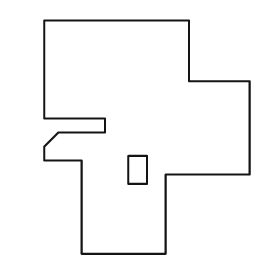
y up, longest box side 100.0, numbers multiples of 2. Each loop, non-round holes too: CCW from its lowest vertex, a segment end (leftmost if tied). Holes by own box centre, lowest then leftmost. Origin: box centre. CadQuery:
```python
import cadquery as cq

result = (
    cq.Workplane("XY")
    .moveTo(-28.0, -50.0)
    .lineTo(8.0, -50.0)
    .lineTo(8.0, -16.0)
    .lineTo(44.0, -16.0)
    .lineTo(44.0, 24.0)
    .lineTo(18.0, 24.0)
    .lineTo(18.0, 50.0)
    .lineTo(-44.0, 50.0)
    .lineTo(-44.0, 8.0)
    .lineTo(-18.0, 8.0)
    .lineTo(-18.0, 2.0)
    .lineTo(-38.0, 2.0)
    .lineTo(-44.0, -4.0)
    .lineTo(-44.0, -10.0)
    .lineTo(-28.0, -10.0)
    .close()
    .moveTo(-8.0, -20.0)
    .lineTo(0.0, -20.0)
    .lineTo(0.0, -8.0)
    .lineTo(-8.0, -8.0)
    .close()
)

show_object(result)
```